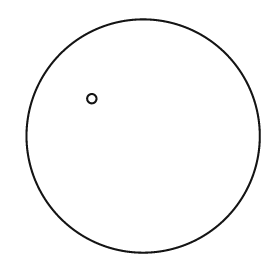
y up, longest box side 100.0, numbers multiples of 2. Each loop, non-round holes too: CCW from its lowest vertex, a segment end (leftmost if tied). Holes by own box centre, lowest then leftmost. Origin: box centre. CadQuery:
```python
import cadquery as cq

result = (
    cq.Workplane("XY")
    .moveTo(0.0, 0.0)
    .circle(50.0)
    .moveTo(-22.0, 16.0)
    .circle(2.0)
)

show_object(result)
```